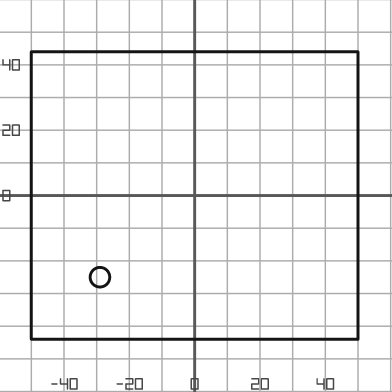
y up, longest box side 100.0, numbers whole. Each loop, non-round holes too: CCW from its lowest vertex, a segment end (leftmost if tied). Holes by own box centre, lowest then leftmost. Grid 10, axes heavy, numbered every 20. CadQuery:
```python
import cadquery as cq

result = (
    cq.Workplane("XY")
    .moveTo(-50.0, -44.0)
    .lineTo(50.0, -44.0)
    .lineTo(50.0, 44.0)
    .lineTo(-50.0, 44.0)
    .close()
    .moveTo(-29.0, -25.0)
    .circle(3.0)
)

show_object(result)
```